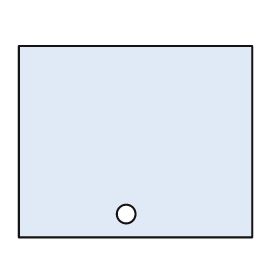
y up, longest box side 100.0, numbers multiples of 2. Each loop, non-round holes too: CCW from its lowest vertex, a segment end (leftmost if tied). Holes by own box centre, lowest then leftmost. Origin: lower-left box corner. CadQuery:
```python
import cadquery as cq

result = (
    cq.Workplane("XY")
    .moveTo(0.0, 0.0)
    .lineTo(100.0, 0.0)
    .lineTo(100.0, 82.0)
    .lineTo(0.0, 82.0)
    .close()
    .moveTo(46.0, 10.0)
    .circle(4.0)
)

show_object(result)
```